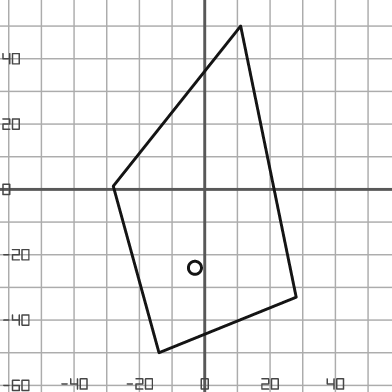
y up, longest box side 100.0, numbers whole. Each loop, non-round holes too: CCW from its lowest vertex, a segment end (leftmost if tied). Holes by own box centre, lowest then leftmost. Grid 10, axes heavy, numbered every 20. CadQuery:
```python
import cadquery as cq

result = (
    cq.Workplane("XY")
    .moveTo(-14.0, -50.0)
    .lineTo(28.0, -33.0)
    .lineTo(11.0, 50.0)
    .lineTo(-28.0, 1.0)
    .close()
    .moveTo(-3.0, -24.0)
    .circle(2.0)
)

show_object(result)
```